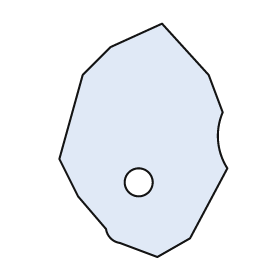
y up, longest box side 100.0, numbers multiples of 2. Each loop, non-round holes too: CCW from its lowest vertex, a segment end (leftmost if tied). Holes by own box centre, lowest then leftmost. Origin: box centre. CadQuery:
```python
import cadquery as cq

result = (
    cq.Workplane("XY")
    .moveTo(6.0, -50.0)
    .lineTo(20.0, -42.0)
    .lineTo(36.0, -12.0)
    .threePointArc((32.0, 0.0), (34.0, 12.0))
    .lineTo(28.0, 28.0)
    .lineTo(8.0, 50.0)
    .lineTo(-14.0, 40.0)
    .lineTo(-26.0, 28.0)
    .lineTo(-36.0, -8.0)
    .lineTo(-28.0, -24.0)
    .lineTo(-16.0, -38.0)
    .threePointArc((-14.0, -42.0), (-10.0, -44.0))
    .close()
    .moveTo(-2.0, -18.0)
    .circle(6.0)
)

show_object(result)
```